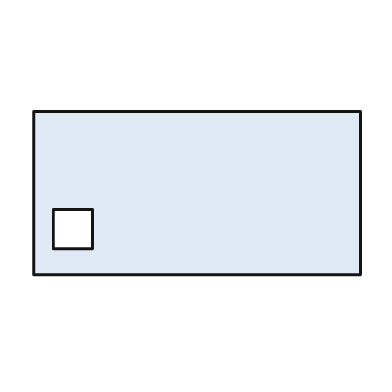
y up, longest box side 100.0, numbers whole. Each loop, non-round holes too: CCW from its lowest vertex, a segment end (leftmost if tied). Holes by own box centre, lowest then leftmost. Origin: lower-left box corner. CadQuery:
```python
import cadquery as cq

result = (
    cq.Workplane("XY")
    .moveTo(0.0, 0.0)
    .lineTo(100.0, 0.0)
    .lineTo(100.0, 50.0)
    .lineTo(0.0, 50.0)
    .close()
    .moveTo(6.0, 8.0)
    .lineTo(18.0, 8.0)
    .lineTo(18.0, 20.0)
    .lineTo(6.0, 20.0)
    .close()
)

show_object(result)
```